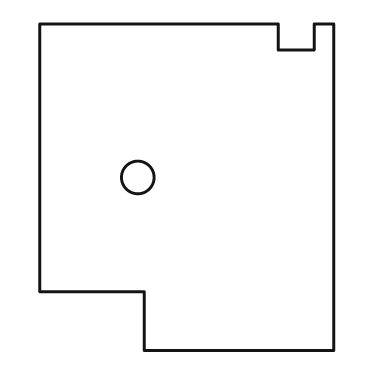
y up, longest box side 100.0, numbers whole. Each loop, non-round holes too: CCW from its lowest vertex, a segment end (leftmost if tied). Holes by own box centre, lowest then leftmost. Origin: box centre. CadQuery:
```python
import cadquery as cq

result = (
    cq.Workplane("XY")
    .moveTo(-13.0, -50.0)
    .lineTo(45.0, -50.0)
    .lineTo(45.0, 50.0)
    .lineTo(39.0, 50.0)
    .lineTo(39.0, 42.0)
    .lineTo(28.0, 42.0)
    .lineTo(28.0, 50.0)
    .lineTo(-45.0, 50.0)
    .lineTo(-45.0, -32.0)
    .lineTo(-13.0, -32.0)
    .close()
    .moveTo(-15.0, 3.0)
    .circle(5.0)
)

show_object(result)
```